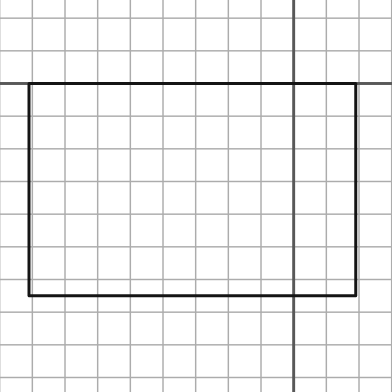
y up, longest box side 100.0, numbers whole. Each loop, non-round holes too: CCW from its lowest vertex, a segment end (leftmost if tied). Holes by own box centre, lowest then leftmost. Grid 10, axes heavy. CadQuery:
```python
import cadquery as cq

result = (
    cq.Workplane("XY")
    .moveTo(-81.0, -65.0)
    .lineTo(19.0, -65.0)
    .lineTo(19.0, 0.0)
    .lineTo(-81.0, 0.0)
    .close()
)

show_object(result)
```